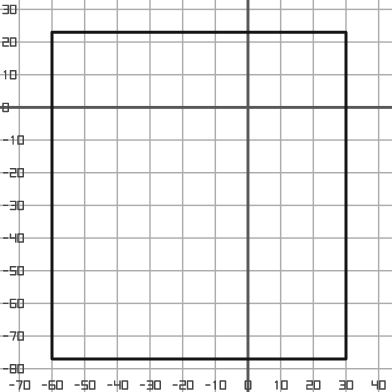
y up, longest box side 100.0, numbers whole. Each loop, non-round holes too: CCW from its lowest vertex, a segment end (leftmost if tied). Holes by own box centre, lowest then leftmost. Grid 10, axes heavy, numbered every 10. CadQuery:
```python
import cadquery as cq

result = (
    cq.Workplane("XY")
    .moveTo(-60.0, -77.0)
    .lineTo(30.0, -77.0)
    .lineTo(30.0, 23.0)
    .lineTo(-60.0, 23.0)
    .close()
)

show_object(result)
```